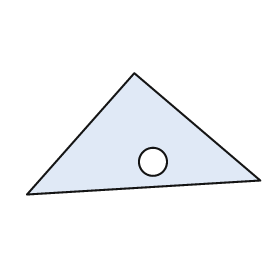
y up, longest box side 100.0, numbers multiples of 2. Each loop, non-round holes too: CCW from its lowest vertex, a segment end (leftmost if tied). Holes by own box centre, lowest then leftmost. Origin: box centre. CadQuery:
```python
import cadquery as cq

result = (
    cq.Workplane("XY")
    .moveTo(-50.0, -26.0)
    .lineTo(50.0, -20.0)
    .lineTo(-4.0, 26.0)
    .close()
    .moveTo(4.0, -12.0)
    .circle(6.0)
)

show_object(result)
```